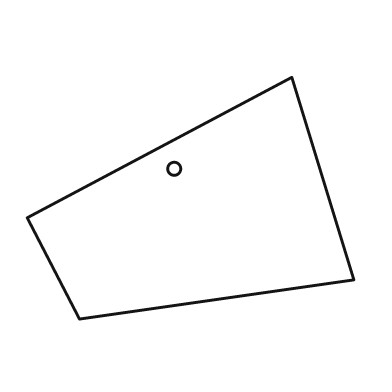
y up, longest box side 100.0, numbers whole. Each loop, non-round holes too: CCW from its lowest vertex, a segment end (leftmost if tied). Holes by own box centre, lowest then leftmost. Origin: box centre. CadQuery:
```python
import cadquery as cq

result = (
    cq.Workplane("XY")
    .moveTo(-34.0, -37.0)
    .lineTo(50.0, -25.0)
    .lineTo(31.0, 37.0)
    .lineTo(-50.0, -6.0)
    .close()
    .moveTo(-5.0, 9.0)
    .circle(2.0)
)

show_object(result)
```